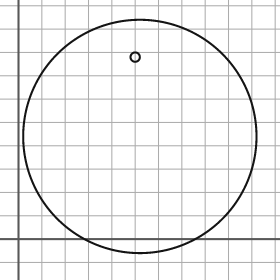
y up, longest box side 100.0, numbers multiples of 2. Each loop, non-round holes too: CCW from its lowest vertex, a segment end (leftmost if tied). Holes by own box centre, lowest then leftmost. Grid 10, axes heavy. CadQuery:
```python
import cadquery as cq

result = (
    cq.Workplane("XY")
    .moveTo(52.0, 44.0)
    .circle(50.0)
    .moveTo(50.0, 78.0)
    .circle(2.0)
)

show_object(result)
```